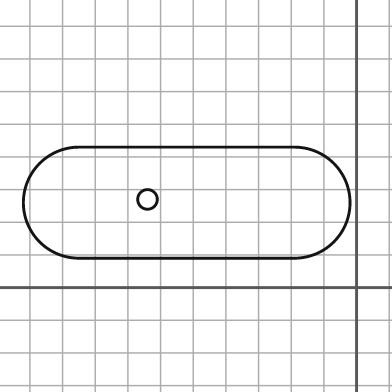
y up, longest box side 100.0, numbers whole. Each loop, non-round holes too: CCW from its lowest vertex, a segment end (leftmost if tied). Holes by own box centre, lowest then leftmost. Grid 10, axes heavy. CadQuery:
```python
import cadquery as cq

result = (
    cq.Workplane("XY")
    .moveTo(-85.0, 9.0)
    .lineTo(-19.0, 9.0)
    .threePointArc((-2.0, 26.0), (-19.0, 43.0))
    .lineTo(-85.0, 43.0)
    .threePointArc((-102.0, 26.0), (-85.0, 9.0))
    .close()
    .moveTo(-64.0, 27.0)
    .circle(3.0)
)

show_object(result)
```